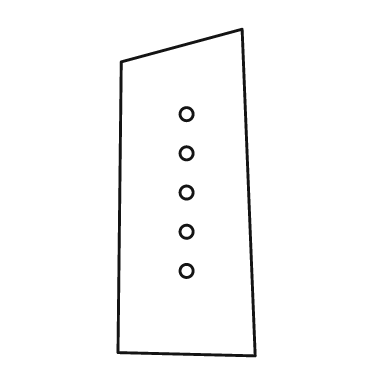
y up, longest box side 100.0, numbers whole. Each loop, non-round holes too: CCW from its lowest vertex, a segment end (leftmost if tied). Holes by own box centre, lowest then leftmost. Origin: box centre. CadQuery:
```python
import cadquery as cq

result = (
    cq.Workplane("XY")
    .moveTo(21.0, -50.0)
    .lineTo(17.0, 50.0)
    .lineTo(-20.0, 40.0)
    .lineTo(-21.0, -49.0)
    .close()
    .moveTo(0.0, -24.0)
    .circle(2.0)
    .moveTo(0.0, -12.0)
    .circle(2.0)
    .moveTo(0.0, 0.0)
    .circle(2.0)
    .moveTo(0.0, 12.0)
    .circle(2.0)
    .moveTo(0.0, 24.0)
    .circle(2.0)
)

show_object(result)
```